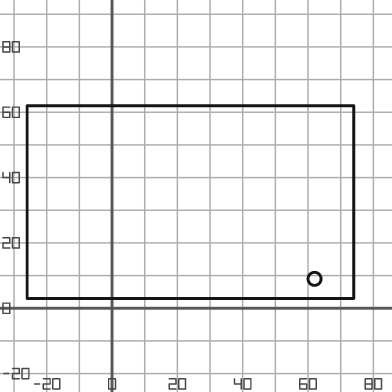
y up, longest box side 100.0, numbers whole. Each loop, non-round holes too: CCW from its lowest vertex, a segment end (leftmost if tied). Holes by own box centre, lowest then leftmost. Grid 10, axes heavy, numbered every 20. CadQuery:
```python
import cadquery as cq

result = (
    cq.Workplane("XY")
    .moveTo(-26.0, 3.0)
    .lineTo(74.0, 3.0)
    .lineTo(74.0, 62.0)
    .lineTo(-26.0, 62.0)
    .close()
    .moveTo(62.0, 9.0)
    .circle(2.0)
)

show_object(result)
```